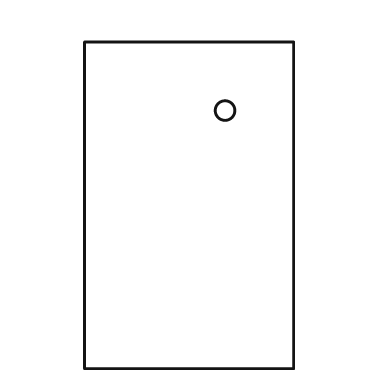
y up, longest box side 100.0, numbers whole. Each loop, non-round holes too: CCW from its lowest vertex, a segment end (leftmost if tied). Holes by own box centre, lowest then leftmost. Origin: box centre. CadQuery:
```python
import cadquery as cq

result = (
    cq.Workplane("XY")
    .moveTo(-32.0, -50.0)
    .lineTo(32.0, -50.0)
    .lineTo(32.0, 50.0)
    .lineTo(-32.0, 50.0)
    .close()
    .moveTo(11.0, 29.0)
    .circle(3.0)
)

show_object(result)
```